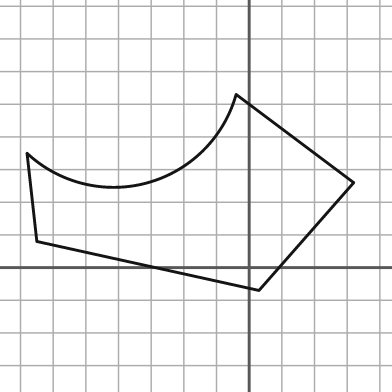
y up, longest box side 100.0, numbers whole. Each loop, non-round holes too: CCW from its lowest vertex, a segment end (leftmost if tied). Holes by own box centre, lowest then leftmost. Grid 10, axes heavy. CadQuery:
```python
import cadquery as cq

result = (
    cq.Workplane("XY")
    .moveTo(3.0, -7.0)
    .lineTo(32.0, 26.0)
    .lineTo(-4.0, 53.0)
    .threePointArc((-31.0, 26.0), (-68.0, 35.0))
    .lineTo(-65.0, 8.0)
    .close()
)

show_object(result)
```